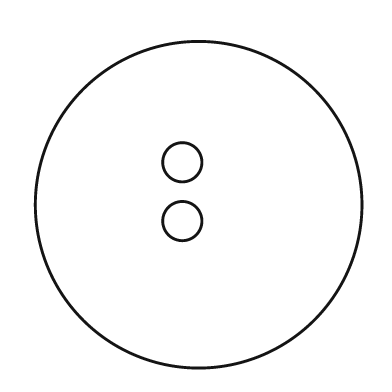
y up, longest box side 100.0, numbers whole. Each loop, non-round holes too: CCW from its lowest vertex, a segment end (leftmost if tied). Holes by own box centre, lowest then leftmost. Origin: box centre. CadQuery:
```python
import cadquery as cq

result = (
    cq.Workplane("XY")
    .moveTo(0.0, 0.0)
    .circle(50.0)
    .moveTo(-5.0, -5.0)
    .circle(6.0)
    .moveTo(-5.0, 13.0)
    .circle(6.0)
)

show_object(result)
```